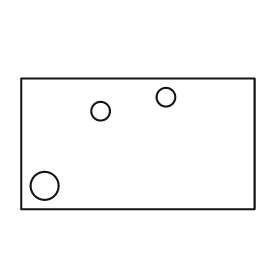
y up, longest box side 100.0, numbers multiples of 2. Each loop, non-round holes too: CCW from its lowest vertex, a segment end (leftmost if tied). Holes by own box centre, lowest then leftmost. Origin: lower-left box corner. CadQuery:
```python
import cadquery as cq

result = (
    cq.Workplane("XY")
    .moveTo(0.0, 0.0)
    .lineTo(100.0, 0.0)
    .lineTo(100.0, 56.0)
    .lineTo(0.0, 56.0)
    .close()
    .moveTo(10.0, 10.0)
    .circle(6.0)
    .moveTo(34.0, 42.0)
    .circle(4.0)
    .moveTo(62.0, 48.0)
    .circle(4.0)
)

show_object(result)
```